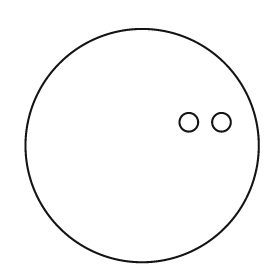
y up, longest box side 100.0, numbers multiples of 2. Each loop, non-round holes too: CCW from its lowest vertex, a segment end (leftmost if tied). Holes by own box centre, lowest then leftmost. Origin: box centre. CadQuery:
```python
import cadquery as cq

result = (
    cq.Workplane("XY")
    .moveTo(0.0, 0.0)
    .circle(50.0)
    .moveTo(20.0, 10.0)
    .circle(4.0)
    .moveTo(34.0, 10.0)
    .circle(4.0)
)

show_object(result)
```